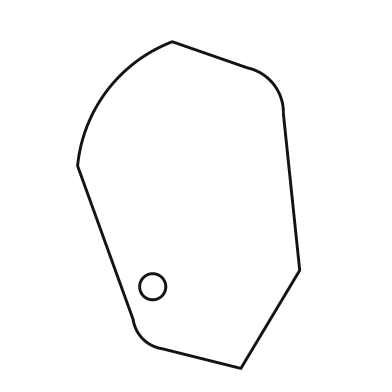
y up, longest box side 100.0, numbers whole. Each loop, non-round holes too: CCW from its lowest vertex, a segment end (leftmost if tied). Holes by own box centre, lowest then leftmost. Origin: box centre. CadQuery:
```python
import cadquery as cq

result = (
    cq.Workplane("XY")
    .moveTo(16.0, -50.0)
    .lineTo(34.0, -20.0)
    .lineTo(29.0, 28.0)
    .threePointArc((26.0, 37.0), (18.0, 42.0))
    .lineTo(-5.0, 50.0)
    .threePointArc((-25.0, 35.0), (-34.0, 12.0))
    .lineTo(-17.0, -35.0)
    .threePointArc((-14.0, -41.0), (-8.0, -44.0))
    .close()
    .moveTo(-11.0, -25.0)
    .circle(4.0)
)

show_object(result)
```